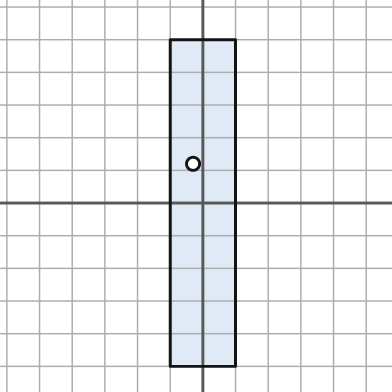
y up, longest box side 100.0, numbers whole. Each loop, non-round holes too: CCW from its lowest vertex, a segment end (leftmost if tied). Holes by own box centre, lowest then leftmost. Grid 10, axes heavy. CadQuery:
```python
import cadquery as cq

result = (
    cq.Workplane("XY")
    .moveTo(-10.0, -50.0)
    .lineTo(10.0, -50.0)
    .lineTo(10.0, 50.0)
    .lineTo(-10.0, 50.0)
    .close()
    .moveTo(-3.0, 12.0)
    .circle(2.0)
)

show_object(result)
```